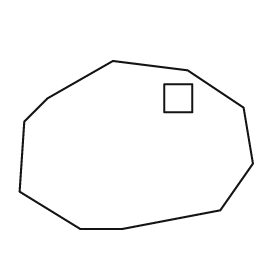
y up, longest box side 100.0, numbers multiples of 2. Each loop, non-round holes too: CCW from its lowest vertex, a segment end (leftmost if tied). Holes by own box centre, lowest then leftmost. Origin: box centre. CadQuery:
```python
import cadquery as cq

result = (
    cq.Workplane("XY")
    .moveTo(-24.0, -36.0)
    .lineTo(-6.0, -36.0)
    .lineTo(36.0, -28.0)
    .lineTo(50.0, -8.0)
    .lineTo(46.0, 16.0)
    .lineTo(22.0, 32.0)
    .lineTo(-10.0, 36.0)
    .lineTo(-38.0, 20.0)
    .lineTo(-48.0, 10.0)
    .lineTo(-50.0, -20.0)
    .close()
    .moveTo(12.0, 14.0)
    .lineTo(24.0, 14.0)
    .lineTo(24.0, 26.0)
    .lineTo(12.0, 26.0)
    .close()
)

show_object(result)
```